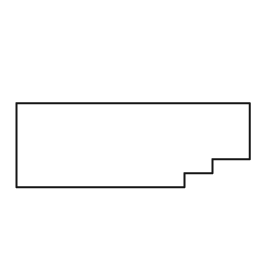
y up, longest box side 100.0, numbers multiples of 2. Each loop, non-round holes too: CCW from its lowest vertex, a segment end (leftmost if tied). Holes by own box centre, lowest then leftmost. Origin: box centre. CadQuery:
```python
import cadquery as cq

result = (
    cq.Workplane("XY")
    .moveTo(-50.0, -18.0)
    .lineTo(22.0, -18.0)
    .lineTo(22.0, -12.0)
    .lineTo(34.0, -12.0)
    .lineTo(34.0, -6.0)
    .lineTo(50.0, -6.0)
    .lineTo(50.0, 18.0)
    .lineTo(-50.0, 18.0)
    .close()
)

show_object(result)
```